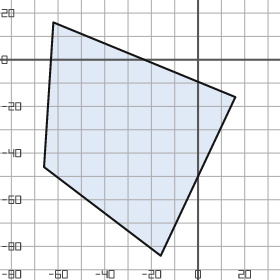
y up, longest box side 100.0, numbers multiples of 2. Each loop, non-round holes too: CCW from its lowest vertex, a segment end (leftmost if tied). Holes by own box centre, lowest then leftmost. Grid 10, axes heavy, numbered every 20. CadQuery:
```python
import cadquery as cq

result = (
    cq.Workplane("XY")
    .moveTo(-16.0, -84.0)
    .lineTo(16.0, -16.0)
    .lineTo(-62.0, 16.0)
    .lineTo(-66.0, -46.0)
    .close()
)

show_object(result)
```